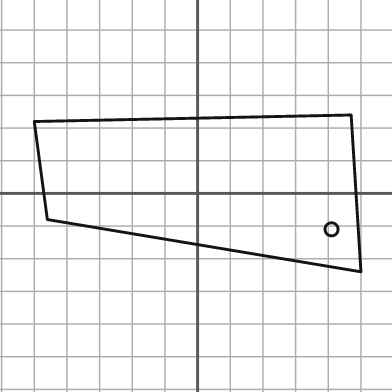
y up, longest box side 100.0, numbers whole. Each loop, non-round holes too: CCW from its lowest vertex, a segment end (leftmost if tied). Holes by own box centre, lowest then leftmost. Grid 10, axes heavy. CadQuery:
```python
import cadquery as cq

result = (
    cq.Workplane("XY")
    .moveTo(50.0, -24.0)
    .lineTo(47.0, 24.0)
    .lineTo(-50.0, 22.0)
    .lineTo(-46.0, -8.0)
    .close()
    .moveTo(41.0, -11.0)
    .circle(2.0)
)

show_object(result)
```